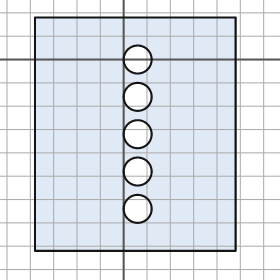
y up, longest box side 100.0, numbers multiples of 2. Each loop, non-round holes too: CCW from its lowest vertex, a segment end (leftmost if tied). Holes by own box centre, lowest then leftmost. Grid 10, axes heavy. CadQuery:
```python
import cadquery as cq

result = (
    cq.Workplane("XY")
    .moveTo(-38.0, -82.0)
    .lineTo(48.0, -82.0)
    .lineTo(48.0, 18.0)
    .lineTo(-38.0, 18.0)
    .close()
    .moveTo(6.0, -64.0)
    .circle(6.0)
    .moveTo(6.0, -48.0)
    .circle(6.0)
    .moveTo(6.0, -32.0)
    .circle(6.0)
    .moveTo(6.0, -16.0)
    .circle(6.0)
    .moveTo(6.0, 0.0)
    .circle(6.0)
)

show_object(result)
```